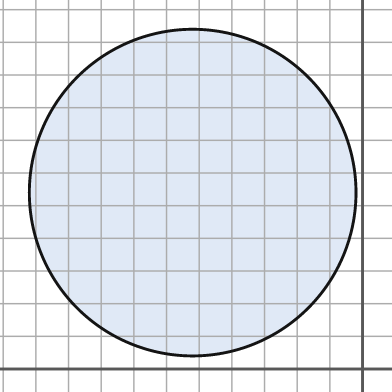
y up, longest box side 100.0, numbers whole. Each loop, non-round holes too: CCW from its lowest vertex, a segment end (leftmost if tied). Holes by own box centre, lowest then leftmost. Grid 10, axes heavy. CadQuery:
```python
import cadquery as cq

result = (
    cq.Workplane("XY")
    .moveTo(-52.0, 54.0)
    .circle(50.0)
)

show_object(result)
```